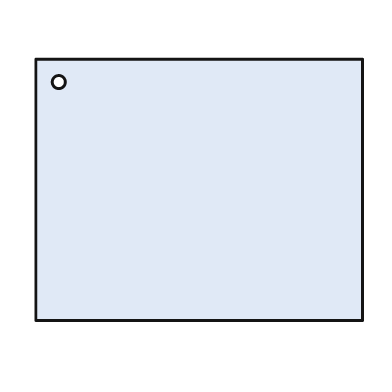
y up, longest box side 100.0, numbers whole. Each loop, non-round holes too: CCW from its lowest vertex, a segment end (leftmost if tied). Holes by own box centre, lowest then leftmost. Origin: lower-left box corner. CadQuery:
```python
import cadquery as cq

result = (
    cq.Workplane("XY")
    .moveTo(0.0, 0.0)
    .lineTo(100.0, 0.0)
    .lineTo(100.0, 80.0)
    .lineTo(0.0, 80.0)
    .close()
    .moveTo(7.0, 73.0)
    .circle(2.0)
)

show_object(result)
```